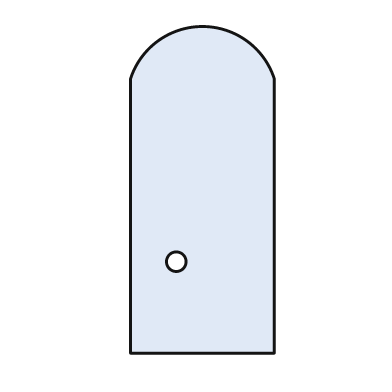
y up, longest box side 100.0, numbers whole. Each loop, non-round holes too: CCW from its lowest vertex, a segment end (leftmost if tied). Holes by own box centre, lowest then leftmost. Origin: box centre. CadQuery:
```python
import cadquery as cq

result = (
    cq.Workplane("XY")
    .moveTo(-22.0, -50.0)
    .lineTo(22.0, -50.0)
    .lineTo(22.0, 34.0)
    .threePointArc((0.0, 50.0), (-22.0, 34.0))
    .close()
    .moveTo(-8.0, -22.0)
    .circle(3.0)
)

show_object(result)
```